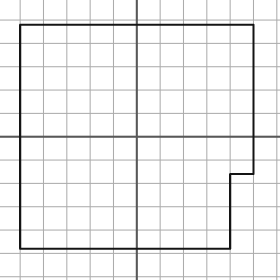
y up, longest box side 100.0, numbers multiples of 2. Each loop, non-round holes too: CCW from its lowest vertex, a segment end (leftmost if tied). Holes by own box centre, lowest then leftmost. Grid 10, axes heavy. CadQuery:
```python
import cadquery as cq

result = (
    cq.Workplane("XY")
    .moveTo(-50.0, -48.0)
    .lineTo(40.0, -48.0)
    .lineTo(40.0, -16.0)
    .lineTo(50.0, -16.0)
    .lineTo(50.0, 48.0)
    .lineTo(-50.0, 48.0)
    .close()
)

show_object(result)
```